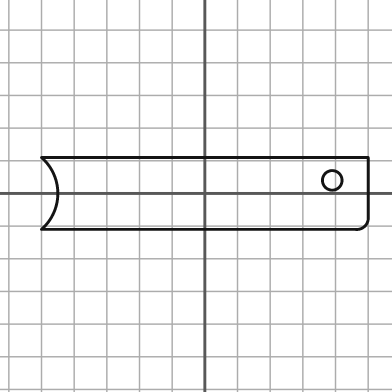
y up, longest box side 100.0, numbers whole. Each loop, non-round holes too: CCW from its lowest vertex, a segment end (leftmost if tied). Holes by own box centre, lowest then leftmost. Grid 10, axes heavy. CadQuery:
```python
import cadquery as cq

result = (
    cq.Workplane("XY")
    .moveTo(-50.0, -11.0)
    .lineTo(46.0, -11.0)
    .threePointArc((49.0, -10.0), (50.0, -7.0))
    .lineTo(50.0, 11.0)
    .lineTo(-50.0, 11.0)
    .threePointArc((-45.0, 0.0), (-50.0, -11.0))
    .close()
    .moveTo(39.0, 4.0)
    .circle(3.0)
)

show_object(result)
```